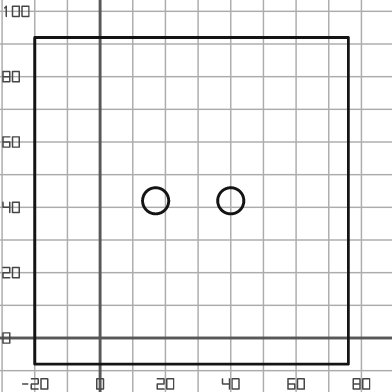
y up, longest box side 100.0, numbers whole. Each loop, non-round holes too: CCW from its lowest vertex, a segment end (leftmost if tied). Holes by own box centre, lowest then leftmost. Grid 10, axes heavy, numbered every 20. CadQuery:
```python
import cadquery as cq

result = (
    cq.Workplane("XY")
    .moveTo(-20.0, -8.0)
    .lineTo(76.0, -8.0)
    .lineTo(76.0, 92.0)
    .lineTo(-20.0, 92.0)
    .close()
    .moveTo(17.0, 42.0)
    .circle(4.0)
    .moveTo(40.0, 42.0)
    .circle(4.0)
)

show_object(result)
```